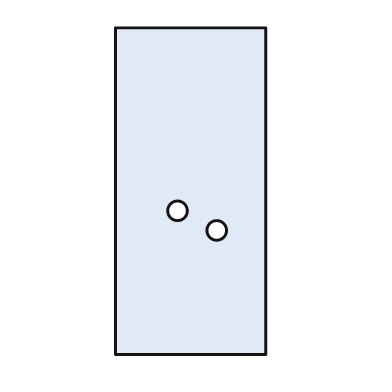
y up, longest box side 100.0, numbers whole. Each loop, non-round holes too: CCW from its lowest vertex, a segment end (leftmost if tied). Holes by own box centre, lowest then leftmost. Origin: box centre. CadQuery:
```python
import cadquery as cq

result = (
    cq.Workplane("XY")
    .moveTo(-23.0, -50.0)
    .lineTo(23.0, -50.0)
    .lineTo(23.0, 50.0)
    .lineTo(-23.0, 50.0)
    .close()
    .moveTo(8.0, -12.0)
    .circle(3.0)
    .moveTo(-4.0, -6.0)
    .circle(3.0)
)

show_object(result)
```